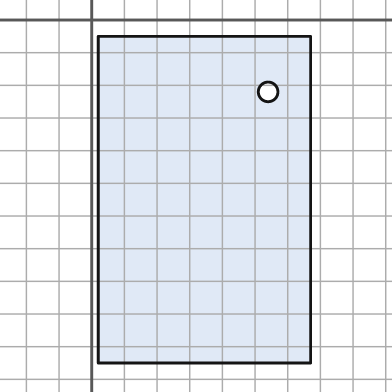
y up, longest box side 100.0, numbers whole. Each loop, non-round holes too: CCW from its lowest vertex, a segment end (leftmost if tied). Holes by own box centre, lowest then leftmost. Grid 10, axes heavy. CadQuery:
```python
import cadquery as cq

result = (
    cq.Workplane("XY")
    .moveTo(2.0, -105.0)
    .lineTo(67.0, -105.0)
    .lineTo(67.0, -5.0)
    .lineTo(2.0, -5.0)
    .close()
    .moveTo(54.0, -22.0)
    .circle(3.0)
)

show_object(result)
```